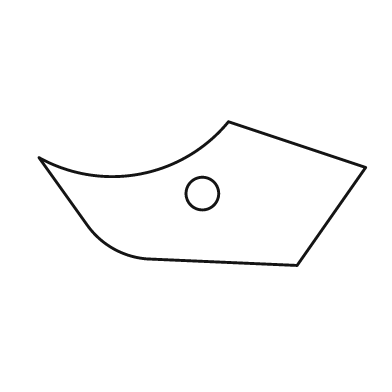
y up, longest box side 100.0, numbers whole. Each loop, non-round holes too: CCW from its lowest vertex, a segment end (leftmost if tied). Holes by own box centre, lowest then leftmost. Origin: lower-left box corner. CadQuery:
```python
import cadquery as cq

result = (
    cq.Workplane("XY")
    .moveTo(79.0, 0.0)
    .lineTo(100.0, 30.0)
    .lineTo(58.0, 44.0)
    .threePointArc((31.0, 28.0), (0.0, 33.0))
    .lineTo(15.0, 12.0)
    .threePointArc((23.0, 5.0), (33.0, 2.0))
    .close()
    .moveTo(50.0, 22.0)
    .circle(5.0)
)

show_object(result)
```